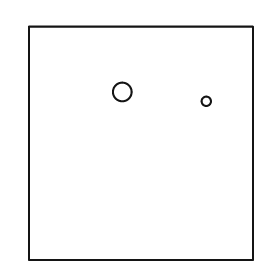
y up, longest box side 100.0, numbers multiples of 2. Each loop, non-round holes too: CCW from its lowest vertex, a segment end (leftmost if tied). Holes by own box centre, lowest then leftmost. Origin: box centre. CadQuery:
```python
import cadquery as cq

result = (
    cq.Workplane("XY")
    .moveTo(-48.0, -50.0)
    .lineTo(48.0, -50.0)
    .lineTo(48.0, 50.0)
    .lineTo(-48.0, 50.0)
    .close()
    .moveTo(28.0, 18.0)
    .circle(2.0)
    .moveTo(-8.0, 22.0)
    .circle(4.0)
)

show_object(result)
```